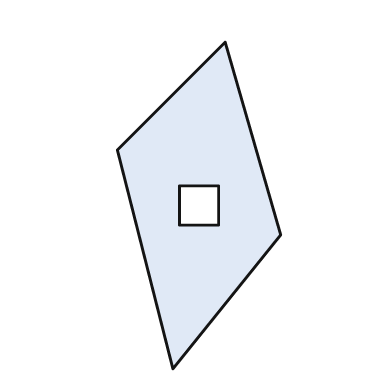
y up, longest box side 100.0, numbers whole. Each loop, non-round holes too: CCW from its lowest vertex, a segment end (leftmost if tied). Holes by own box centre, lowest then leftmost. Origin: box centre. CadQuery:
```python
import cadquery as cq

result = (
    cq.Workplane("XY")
    .moveTo(-8.0, -50.0)
    .lineTo(25.0, -9.0)
    .lineTo(8.0, 50.0)
    .lineTo(-25.0, 17.0)
    .close()
    .moveTo(-6.0, -6.0)
    .lineTo(6.0, -6.0)
    .lineTo(6.0, 6.0)
    .lineTo(-6.0, 6.0)
    .close()
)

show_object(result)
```